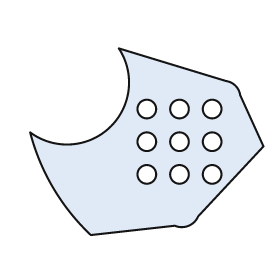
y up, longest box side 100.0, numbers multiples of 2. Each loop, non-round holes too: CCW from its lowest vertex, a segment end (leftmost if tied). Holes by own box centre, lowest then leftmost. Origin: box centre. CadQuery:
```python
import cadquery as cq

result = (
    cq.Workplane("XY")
    .moveTo(-24.0, -40.0)
    .lineTo(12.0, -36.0)
    .threePointArc((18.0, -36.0), (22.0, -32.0))
    .lineTo(50.0, -2.0)
    .lineTo(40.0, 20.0)
    .threePointArc((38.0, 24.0), (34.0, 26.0))
    .lineTo(-12.0, 40.0)
    .threePointArc((-16.0, 6.0), (-50.0, 4.0))
    .threePointArc((-40.0, -20.0), (-24.0, -40.0))
    .close()
    .moveTo(0.0, -14.0)
    .circle(4.0)
    .moveTo(14.0, -14.0)
    .circle(4.0)
    .moveTo(28.0, -14.0)
    .circle(4.0)
    .moveTo(0.0, 0.0)
    .circle(4.0)
    .moveTo(14.0, 0.0)
    .circle(4.0)
    .moveTo(28.0, 0.0)
    .circle(4.0)
    .moveTo(0.0, 14.0)
    .circle(4.0)
    .moveTo(14.0, 14.0)
    .circle(4.0)
    .moveTo(28.0, 14.0)
    .circle(4.0)
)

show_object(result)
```